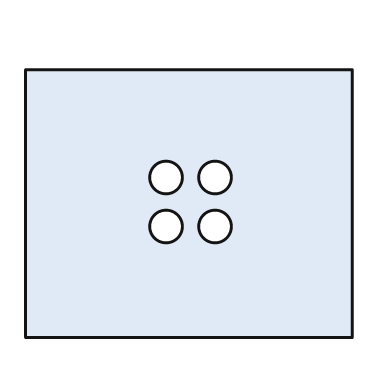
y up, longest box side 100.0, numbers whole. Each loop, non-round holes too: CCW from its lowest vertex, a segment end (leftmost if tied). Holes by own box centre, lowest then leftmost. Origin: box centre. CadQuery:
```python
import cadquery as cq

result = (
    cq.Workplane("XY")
    .moveTo(-50.0, -41.0)
    .lineTo(50.0, -41.0)
    .lineTo(50.0, 41.0)
    .lineTo(-50.0, 41.0)
    .close()
    .moveTo(-7.0, -7.0)
    .circle(5.0)
    .moveTo(8.0, -7.0)
    .circle(5.0)
    .moveTo(-7.0, 8.0)
    .circle(5.0)
    .moveTo(8.0, 8.0)
    .circle(5.0)
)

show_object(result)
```